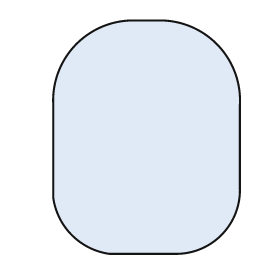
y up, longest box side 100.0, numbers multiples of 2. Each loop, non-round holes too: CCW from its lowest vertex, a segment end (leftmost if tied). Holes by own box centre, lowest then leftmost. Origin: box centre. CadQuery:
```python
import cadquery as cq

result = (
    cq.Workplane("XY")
    .moveTo(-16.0, -50.0)
    .lineTo(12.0, -50.0)
    .threePointArc((32.0, -42.0), (40.0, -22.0))
    .lineTo(40.0, 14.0)
    .threePointArc((30.0, 40.0), (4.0, 50.0))
    .lineTo(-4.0, 50.0)
    .threePointArc((-30.0, 40.0), (-40.0, 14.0))
    .lineTo(-40.0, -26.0)
    .threePointArc((-32.0, -42.0), (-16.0, -50.0))
    .close()
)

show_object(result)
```